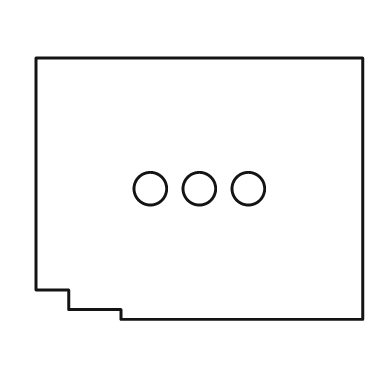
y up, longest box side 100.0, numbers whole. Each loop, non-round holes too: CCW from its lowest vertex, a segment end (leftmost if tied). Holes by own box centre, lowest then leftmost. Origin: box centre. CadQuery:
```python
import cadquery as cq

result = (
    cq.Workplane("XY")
    .moveTo(-24.0, -40.0)
    .lineTo(50.0, -40.0)
    .lineTo(50.0, 40.0)
    .lineTo(-50.0, 40.0)
    .lineTo(-50.0, -31.0)
    .lineTo(-40.0, -31.0)
    .lineTo(-40.0, -37.0)
    .lineTo(-24.0, -37.0)
    .close()
    .moveTo(-15.0, 0.0)
    .circle(5.0)
    .moveTo(0.0, 0.0)
    .circle(5.0)
    .moveTo(15.0, 0.0)
    .circle(5.0)
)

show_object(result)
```